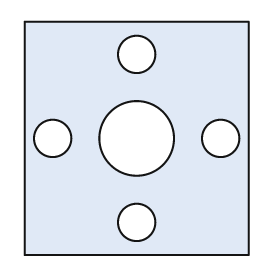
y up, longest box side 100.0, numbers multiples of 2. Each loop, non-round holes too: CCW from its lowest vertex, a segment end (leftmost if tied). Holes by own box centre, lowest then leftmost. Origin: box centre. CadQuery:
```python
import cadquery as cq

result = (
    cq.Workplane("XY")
    .moveTo(-48.0, -50.0)
    .lineTo(48.0, -50.0)
    .lineTo(48.0, 50.0)
    .lineTo(-48.0, 50.0)
    .close()
    .moveTo(0.0, -36.0)
    .circle(8.0)
    .moveTo(-36.0, 0.0)
    .circle(8.0)
    .moveTo(0.0, 0.0)
    .circle(16.0)
    .moveTo(36.0, 0.0)
    .circle(8.0)
    .moveTo(0.0, 36.0)
    .circle(8.0)
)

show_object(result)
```